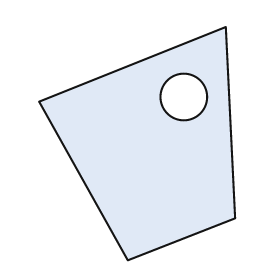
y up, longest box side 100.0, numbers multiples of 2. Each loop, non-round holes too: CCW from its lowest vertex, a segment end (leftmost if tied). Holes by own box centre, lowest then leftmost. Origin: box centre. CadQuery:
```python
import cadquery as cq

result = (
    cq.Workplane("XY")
    .moveTo(-4.0, -50.0)
    .lineTo(42.0, -32.0)
    .lineTo(38.0, 50.0)
    .lineTo(-42.0, 18.0)
    .close()
    .moveTo(20.0, 20.0)
    .circle(10.0)
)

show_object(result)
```